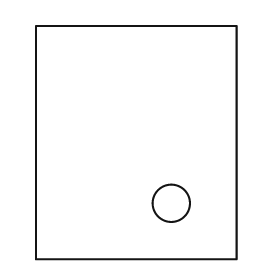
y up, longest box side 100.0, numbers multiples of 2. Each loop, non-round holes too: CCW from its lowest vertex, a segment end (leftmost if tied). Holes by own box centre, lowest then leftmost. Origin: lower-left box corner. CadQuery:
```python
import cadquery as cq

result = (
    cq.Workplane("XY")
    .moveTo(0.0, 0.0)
    .lineTo(86.0, 0.0)
    .lineTo(86.0, 100.0)
    .lineTo(0.0, 100.0)
    .close()
    .moveTo(58.0, 24.0)
    .circle(8.0)
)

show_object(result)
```